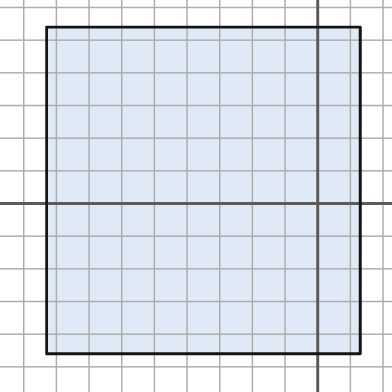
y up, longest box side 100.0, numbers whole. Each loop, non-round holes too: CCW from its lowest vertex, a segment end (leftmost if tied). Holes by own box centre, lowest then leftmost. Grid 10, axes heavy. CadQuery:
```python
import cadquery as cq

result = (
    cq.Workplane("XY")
    .moveTo(-83.0, -46.0)
    .lineTo(13.0, -46.0)
    .lineTo(13.0, 54.0)
    .lineTo(-83.0, 54.0)
    .close()
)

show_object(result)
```